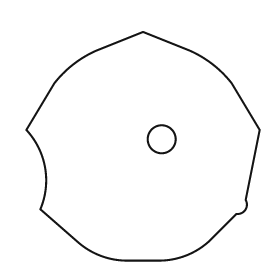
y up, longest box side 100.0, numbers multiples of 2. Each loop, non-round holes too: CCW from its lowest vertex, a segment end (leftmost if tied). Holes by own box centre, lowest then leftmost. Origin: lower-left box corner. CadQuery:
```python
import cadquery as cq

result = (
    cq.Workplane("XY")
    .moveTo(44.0, 0.0)
    .lineTo(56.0, 0.0)
    .threePointArc((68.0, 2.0), (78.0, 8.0))
    .lineTo(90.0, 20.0)
    .threePointArc((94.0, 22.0), (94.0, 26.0))
    .lineTo(100.0, 56.0)
    .lineTo(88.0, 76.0)
    .threePointArc((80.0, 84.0), (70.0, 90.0))
    .lineTo(50.0, 98.0)
    .lineTo(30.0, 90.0)
    .threePointArc((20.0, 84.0), (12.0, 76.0))
    .lineTo(0.0, 56.0)
    .threePointArc((8.0, 40.0), (6.0, 22.0))
    .lineTo(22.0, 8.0)
    .threePointArc((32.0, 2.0), (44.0, 0.0))
    .close()
    .moveTo(58.0, 52.0)
    .circle(6.0)
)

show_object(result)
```